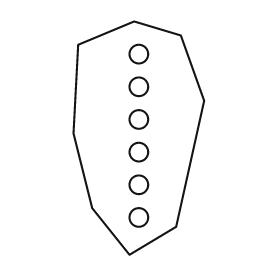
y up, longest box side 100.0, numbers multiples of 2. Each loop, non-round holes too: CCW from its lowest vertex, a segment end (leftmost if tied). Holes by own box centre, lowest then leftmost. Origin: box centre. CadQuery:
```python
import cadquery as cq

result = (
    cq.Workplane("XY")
    .moveTo(-4.0, -50.0)
    .lineTo(16.0, -38.0)
    .lineTo(28.0, 16.0)
    .lineTo(18.0, 44.0)
    .lineTo(-2.0, 50.0)
    .lineTo(-26.0, 40.0)
    .lineTo(-28.0, 2.0)
    .lineTo(-20.0, -30.0)
    .close()
    .moveTo(0.0, -34.0)
    .circle(4.0)
    .moveTo(0.0, -20.0)
    .circle(4.0)
    .moveTo(0.0, -6.0)
    .circle(4.0)
    .moveTo(0.0, 8.0)
    .circle(4.0)
    .moveTo(0.0, 22.0)
    .circle(4.0)
    .moveTo(0.0, 36.0)
    .circle(4.0)
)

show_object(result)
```